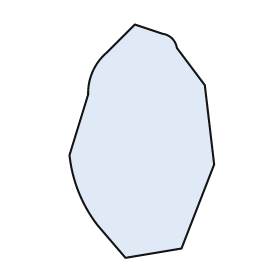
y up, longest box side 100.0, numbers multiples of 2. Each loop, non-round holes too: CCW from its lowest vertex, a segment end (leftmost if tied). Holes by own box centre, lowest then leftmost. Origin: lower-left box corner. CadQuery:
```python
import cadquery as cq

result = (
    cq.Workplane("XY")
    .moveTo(24.0, 0.0)
    .lineTo(48.0, 4.0)
    .lineTo(62.0, 40.0)
    .lineTo(58.0, 74.0)
    .lineTo(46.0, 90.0)
    .threePointArc((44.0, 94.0), (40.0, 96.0))
    .lineTo(28.0, 100.0)
    .lineTo(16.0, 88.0)
    .threePointArc((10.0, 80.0), (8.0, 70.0))
    .lineTo(0.0, 44.0)
    .threePointArc((4.0, 28.0), (12.0, 14.0))
    .close()
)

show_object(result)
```